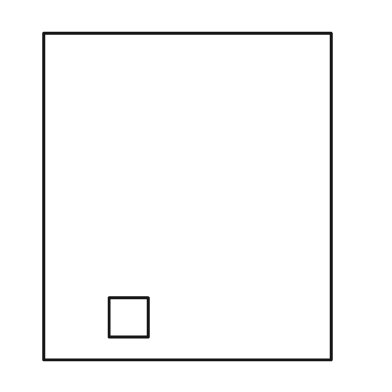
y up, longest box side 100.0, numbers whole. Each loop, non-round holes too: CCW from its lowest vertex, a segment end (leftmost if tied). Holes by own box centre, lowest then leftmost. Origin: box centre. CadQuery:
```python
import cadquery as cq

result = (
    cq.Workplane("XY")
    .moveTo(-44.0, -50.0)
    .lineTo(44.0, -50.0)
    .lineTo(44.0, 50.0)
    .lineTo(-44.0, 50.0)
    .close()
    .moveTo(-24.0, -43.0)
    .lineTo(-12.0, -43.0)
    .lineTo(-12.0, -31.0)
    .lineTo(-24.0, -31.0)
    .close()
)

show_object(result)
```